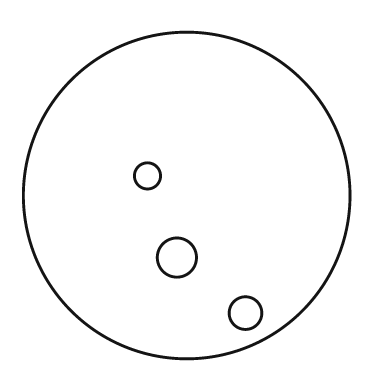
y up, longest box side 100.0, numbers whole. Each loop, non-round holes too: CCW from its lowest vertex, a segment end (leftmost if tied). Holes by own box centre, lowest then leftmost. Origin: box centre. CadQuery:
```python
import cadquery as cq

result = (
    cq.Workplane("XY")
    .moveTo(0.0, 0.0)
    .circle(50.0)
    .moveTo(18.0, -36.0)
    .circle(5.0)
    .moveTo(-3.0, -19.0)
    .circle(6.0)
    .moveTo(-12.0, 6.0)
    .circle(4.0)
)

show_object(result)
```